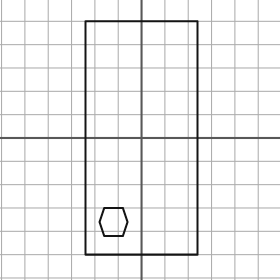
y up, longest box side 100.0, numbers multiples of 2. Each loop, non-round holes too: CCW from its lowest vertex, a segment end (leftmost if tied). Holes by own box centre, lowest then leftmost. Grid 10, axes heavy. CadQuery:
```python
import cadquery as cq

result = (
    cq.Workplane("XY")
    .moveTo(-24.0, -50.0)
    .lineTo(24.0, -50.0)
    .lineTo(24.0, 50.0)
    .lineTo(-24.0, 50.0)
    .close()
    .moveTo(-16.0, -42.0)
    .lineTo(-8.0, -42.0)
    .lineTo(-6.0, -36.0)
    .lineTo(-8.0, -30.0)
    .lineTo(-16.0, -30.0)
    .lineTo(-18.0, -36.0)
    .close()
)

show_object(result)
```